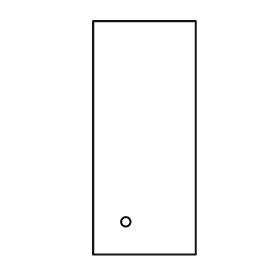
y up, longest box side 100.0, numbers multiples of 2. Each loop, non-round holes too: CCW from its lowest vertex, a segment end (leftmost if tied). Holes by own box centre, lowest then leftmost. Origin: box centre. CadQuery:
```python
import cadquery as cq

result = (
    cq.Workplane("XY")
    .moveTo(-22.0, -50.0)
    .lineTo(22.0, -50.0)
    .lineTo(22.0, 50.0)
    .lineTo(-22.0, 50.0)
    .close()
    .moveTo(-8.0, -36.0)
    .circle(2.0)
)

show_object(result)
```